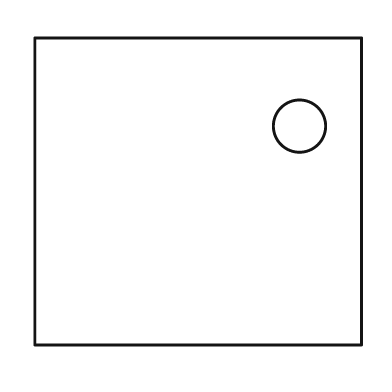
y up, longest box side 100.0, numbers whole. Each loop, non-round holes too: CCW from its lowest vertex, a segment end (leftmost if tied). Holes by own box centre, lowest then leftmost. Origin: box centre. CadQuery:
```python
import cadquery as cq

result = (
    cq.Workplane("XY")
    .moveTo(-50.0, -47.0)
    .lineTo(50.0, -47.0)
    .lineTo(50.0, 47.0)
    .lineTo(-50.0, 47.0)
    .close()
    .moveTo(31.0, 20.0)
    .circle(8.0)
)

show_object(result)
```